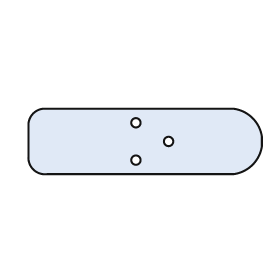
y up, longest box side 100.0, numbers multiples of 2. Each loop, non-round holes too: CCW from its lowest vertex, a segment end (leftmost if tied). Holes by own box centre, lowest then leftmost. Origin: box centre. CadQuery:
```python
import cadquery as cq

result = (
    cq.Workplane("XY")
    .moveTo(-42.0, -14.0)
    .lineTo(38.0, -14.0)
    .threePointArc((46.0, -10.0), (50.0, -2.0))
    .lineTo(50.0, 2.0)
    .threePointArc((46.0, 10.0), (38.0, 14.0))
    .lineTo(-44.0, 14.0)
    .threePointArc((-48.0, 12.0), (-50.0, 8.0))
    .lineTo(-50.0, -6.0)
    .threePointArc((-48.0, -12.0), (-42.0, -14.0))
    .close()
    .moveTo(-4.0, -8.0)
    .circle(2.0)
    .moveTo(10.0, 0.0)
    .circle(2.0)
    .moveTo(-4.0, 8.0)
    .circle(2.0)
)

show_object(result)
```